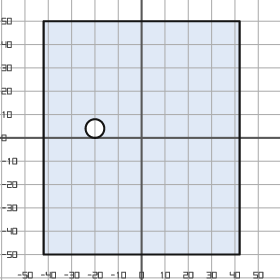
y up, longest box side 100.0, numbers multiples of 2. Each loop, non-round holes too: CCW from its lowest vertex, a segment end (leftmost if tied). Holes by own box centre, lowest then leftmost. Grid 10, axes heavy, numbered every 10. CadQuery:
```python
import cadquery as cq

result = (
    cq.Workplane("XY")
    .moveTo(-42.0, -50.0)
    .lineTo(42.0, -50.0)
    .lineTo(42.0, 50.0)
    .lineTo(-42.0, 50.0)
    .close()
    .moveTo(-20.0, 4.0)
    .circle(4.0)
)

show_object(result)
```